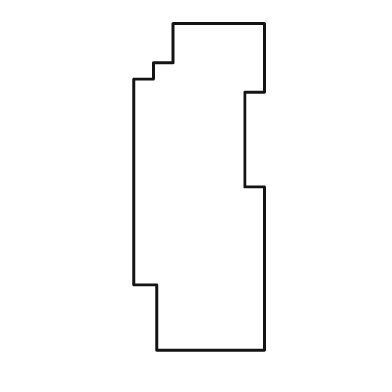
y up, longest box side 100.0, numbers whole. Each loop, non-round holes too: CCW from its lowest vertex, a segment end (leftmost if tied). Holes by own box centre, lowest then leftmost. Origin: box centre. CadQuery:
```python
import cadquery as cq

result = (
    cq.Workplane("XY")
    .moveTo(-13.0, -50.0)
    .lineTo(20.0, -50.0)
    .lineTo(20.0, 0.0)
    .lineTo(14.0, 0.0)
    .lineTo(14.0, 29.0)
    .lineTo(20.0, 29.0)
    .lineTo(20.0, 50.0)
    .lineTo(-8.0, 50.0)
    .lineTo(-8.0, 38.0)
    .lineTo(-14.0, 38.0)
    .lineTo(-14.0, 33.0)
    .lineTo(-20.0, 33.0)
    .lineTo(-20.0, -30.0)
    .lineTo(-13.0, -30.0)
    .close()
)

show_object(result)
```